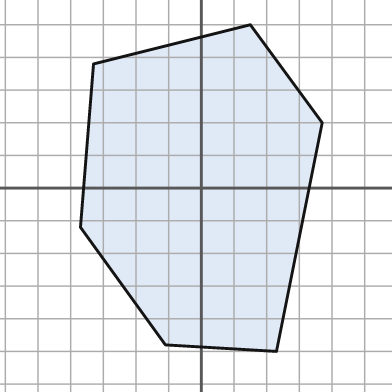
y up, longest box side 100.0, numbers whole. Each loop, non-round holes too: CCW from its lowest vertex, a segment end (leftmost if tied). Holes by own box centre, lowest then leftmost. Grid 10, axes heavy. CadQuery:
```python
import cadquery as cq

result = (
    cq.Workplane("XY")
    .moveTo(23.0, -50.0)
    .lineTo(37.0, 20.0)
    .lineTo(15.0, 50.0)
    .lineTo(-33.0, 38.0)
    .lineTo(-37.0, -12.0)
    .lineTo(-11.0, -48.0)
    .close()
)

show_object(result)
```